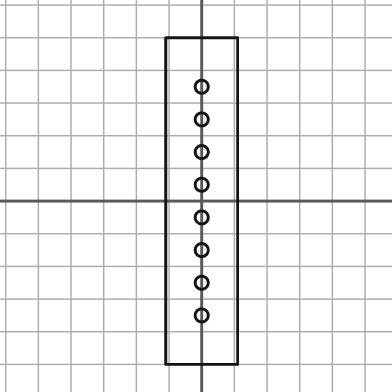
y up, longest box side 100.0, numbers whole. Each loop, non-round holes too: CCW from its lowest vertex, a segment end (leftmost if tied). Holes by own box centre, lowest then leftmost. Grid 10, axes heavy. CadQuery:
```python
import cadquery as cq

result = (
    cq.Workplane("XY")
    .moveTo(-11.0, -50.0)
    .lineTo(11.0, -50.0)
    .lineTo(11.0, 50.0)
    .lineTo(-11.0, 50.0)
    .close()
    .moveTo(0.0, -35.0)
    .circle(2.0)
    .moveTo(0.0, -25.0)
    .circle(2.0)
    .moveTo(0.0, -15.0)
    .circle(2.0)
    .moveTo(0.0, -5.0)
    .circle(2.0)
    .moveTo(0.0, 5.0)
    .circle(2.0)
    .moveTo(0.0, 15.0)
    .circle(2.0)
    .moveTo(0.0, 25.0)
    .circle(2.0)
    .moveTo(0.0, 35.0)
    .circle(2.0)
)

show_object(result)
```